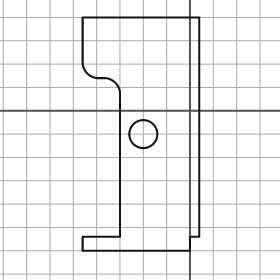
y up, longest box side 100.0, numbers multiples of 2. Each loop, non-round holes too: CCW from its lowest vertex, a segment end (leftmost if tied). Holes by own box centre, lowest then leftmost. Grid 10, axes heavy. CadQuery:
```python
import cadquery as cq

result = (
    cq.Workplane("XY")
    .moveTo(-46.0, -60.0)
    .lineTo(0.0, -60.0)
    .lineTo(0.0, -54.0)
    .lineTo(4.0, -54.0)
    .lineTo(4.0, 40.0)
    .lineTo(-46.0, 40.0)
    .lineTo(-46.0, 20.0)
    .threePointArc((-44.0, 16.0), (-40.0, 14.0))
    .lineTo(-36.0, 14.0)
    .threePointArc((-32.0, 12.0), (-30.0, 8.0))
    .lineTo(-30.0, -54.0)
    .lineTo(-46.0, -54.0)
    .close()
    .moveTo(-20.0, -10.0)
    .circle(6.0)
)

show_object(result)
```